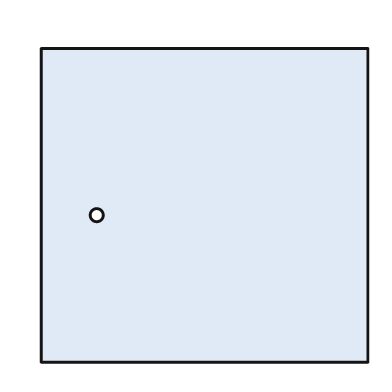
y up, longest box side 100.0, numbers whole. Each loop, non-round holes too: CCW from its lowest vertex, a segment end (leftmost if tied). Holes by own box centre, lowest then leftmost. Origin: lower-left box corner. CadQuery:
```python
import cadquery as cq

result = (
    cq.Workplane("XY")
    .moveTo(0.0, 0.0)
    .lineTo(100.0, 0.0)
    .lineTo(100.0, 96.0)
    .lineTo(0.0, 96.0)
    .close()
    .moveTo(17.0, 45.0)
    .circle(2.0)
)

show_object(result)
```